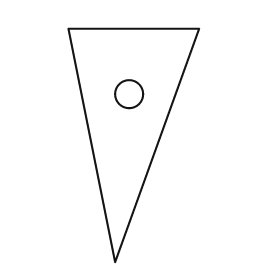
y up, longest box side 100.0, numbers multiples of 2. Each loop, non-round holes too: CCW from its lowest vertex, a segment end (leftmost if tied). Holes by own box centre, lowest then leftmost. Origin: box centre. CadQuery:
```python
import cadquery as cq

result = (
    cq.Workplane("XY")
    .moveTo(-8.0, -50.0)
    .lineTo(28.0, 50.0)
    .lineTo(-28.0, 50.0)
    .close()
    .moveTo(-2.0, 22.0)
    .circle(6.0)
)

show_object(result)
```